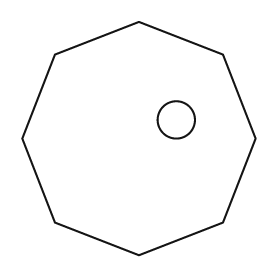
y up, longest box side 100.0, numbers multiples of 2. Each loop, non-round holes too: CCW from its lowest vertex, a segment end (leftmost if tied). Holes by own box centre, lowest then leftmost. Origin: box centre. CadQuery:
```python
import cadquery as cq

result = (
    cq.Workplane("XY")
    .moveTo(0.0, -50.0)
    .lineTo(36.0, -36.0)
    .lineTo(50.0, 0.0)
    .lineTo(36.0, 36.0)
    .lineTo(0.0, 50.0)
    .lineTo(-36.0, 36.0)
    .lineTo(-50.0, 0.0)
    .lineTo(-36.0, -36.0)
    .close()
    .moveTo(16.0, 8.0)
    .circle(8.0)
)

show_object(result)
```